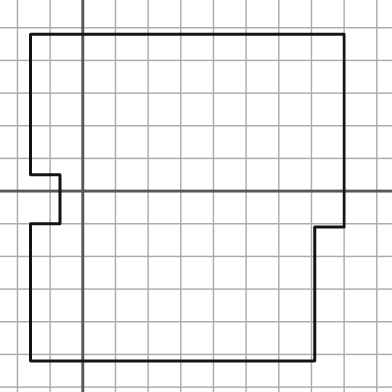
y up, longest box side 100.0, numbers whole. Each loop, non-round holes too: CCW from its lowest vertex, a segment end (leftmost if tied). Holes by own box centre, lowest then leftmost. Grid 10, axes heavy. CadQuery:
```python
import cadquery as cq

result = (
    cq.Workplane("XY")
    .moveTo(-16.0, -52.0)
    .lineTo(71.0, -52.0)
    .lineTo(71.0, -11.0)
    .lineTo(80.0, -11.0)
    .lineTo(80.0, 48.0)
    .lineTo(-16.0, 48.0)
    .lineTo(-16.0, 5.0)
    .lineTo(-7.0, 5.0)
    .lineTo(-7.0, -10.0)
    .lineTo(-16.0, -10.0)
    .close()
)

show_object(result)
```